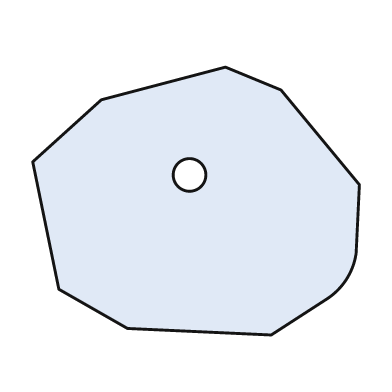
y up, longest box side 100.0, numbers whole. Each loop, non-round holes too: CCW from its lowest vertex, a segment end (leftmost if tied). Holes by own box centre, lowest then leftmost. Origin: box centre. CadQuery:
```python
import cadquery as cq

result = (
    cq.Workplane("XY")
    .moveTo(23.0, -41.0)
    .lineTo(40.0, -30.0)
    .threePointArc((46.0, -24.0), (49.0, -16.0))
    .lineTo(50.0, 5.0)
    .lineTo(26.0, 34.0)
    .lineTo(9.0, 41.0)
    .lineTo(-29.0, 31.0)
    .lineTo(-50.0, 12.0)
    .lineTo(-42.0, -27.0)
    .lineTo(-21.0, -39.0)
    .close()
    .moveTo(-2.0, 8.0)
    .circle(5.0)
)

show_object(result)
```